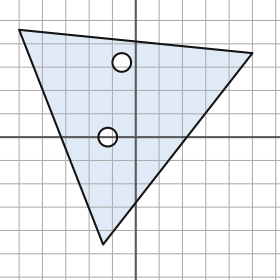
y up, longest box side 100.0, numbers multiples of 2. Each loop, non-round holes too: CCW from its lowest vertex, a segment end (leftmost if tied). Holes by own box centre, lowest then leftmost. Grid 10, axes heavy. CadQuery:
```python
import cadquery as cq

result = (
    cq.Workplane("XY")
    .moveTo(-14.0, -46.0)
    .lineTo(50.0, 36.0)
    .lineTo(-50.0, 46.0)
    .close()
    .moveTo(-12.0, 0.0)
    .circle(4.0)
    .moveTo(-6.0, 32.0)
    .circle(4.0)
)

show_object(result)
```